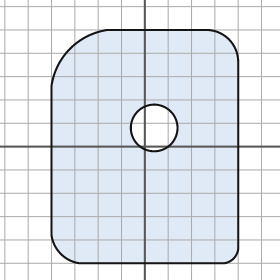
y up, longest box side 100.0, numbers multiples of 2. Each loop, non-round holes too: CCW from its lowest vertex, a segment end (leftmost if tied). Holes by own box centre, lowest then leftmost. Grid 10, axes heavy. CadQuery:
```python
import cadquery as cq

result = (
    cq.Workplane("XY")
    .moveTo(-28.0, -50.0)
    .lineTo(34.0, -50.0)
    .threePointArc((38.0, -48.0), (40.0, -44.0))
    .lineTo(40.0, 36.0)
    .threePointArc((36.0, 46.0), (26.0, 50.0))
    .lineTo(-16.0, 50.0)
    .threePointArc((-32.0, 42.0), (-40.0, 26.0))
    .lineTo(-40.0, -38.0)
    .threePointArc((-36.0, -46.0), (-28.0, -50.0))
    .close()
    .moveTo(4.0, 8.0)
    .circle(10.0)
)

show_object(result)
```